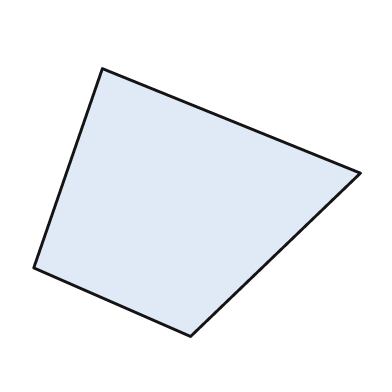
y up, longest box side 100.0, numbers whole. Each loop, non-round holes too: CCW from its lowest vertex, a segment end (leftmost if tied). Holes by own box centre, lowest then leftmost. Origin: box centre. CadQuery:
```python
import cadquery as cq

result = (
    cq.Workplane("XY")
    .moveTo(-2.0, -41.0)
    .lineTo(50.0, 9.0)
    .lineTo(-29.0, 41.0)
    .lineTo(-50.0, -20.0)
    .close()
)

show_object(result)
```